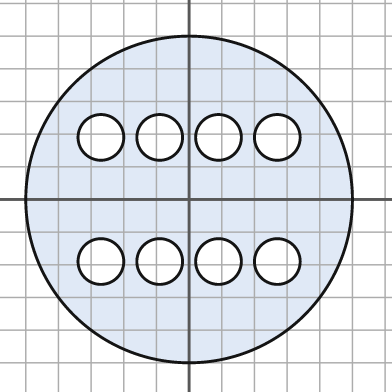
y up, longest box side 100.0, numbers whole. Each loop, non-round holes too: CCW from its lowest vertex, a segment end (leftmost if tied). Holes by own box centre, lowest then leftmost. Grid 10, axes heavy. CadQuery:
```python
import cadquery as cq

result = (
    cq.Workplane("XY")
    .moveTo(0.0, 0.0)
    .circle(50.0)
    .moveTo(-27.0, -19.0)
    .circle(7.0)
    .moveTo(-9.0, -19.0)
    .circle(7.0)
    .moveTo(9.0, -19.0)
    .circle(7.0)
    .moveTo(27.0, -19.0)
    .circle(7.0)
    .moveTo(-27.0, 19.0)
    .circle(7.0)
    .moveTo(-9.0, 19.0)
    .circle(7.0)
    .moveTo(9.0, 19.0)
    .circle(7.0)
    .moveTo(27.0, 19.0)
    .circle(7.0)
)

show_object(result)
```